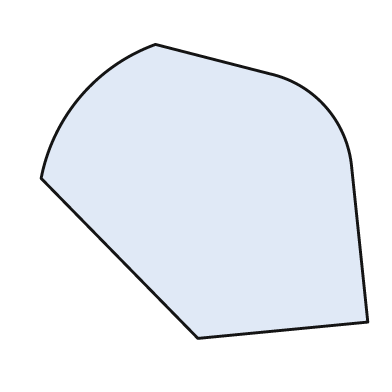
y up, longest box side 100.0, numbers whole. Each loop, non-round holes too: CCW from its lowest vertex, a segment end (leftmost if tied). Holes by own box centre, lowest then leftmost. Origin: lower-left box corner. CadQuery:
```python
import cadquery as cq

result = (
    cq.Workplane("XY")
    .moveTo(48.0, 0.0)
    .lineTo(100.0, 5.0)
    .lineTo(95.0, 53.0)
    .threePointArc((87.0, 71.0), (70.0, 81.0))
    .lineTo(35.0, 90.0)
    .threePointArc((12.0, 74.0), (0.0, 49.0))
    .close()
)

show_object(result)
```